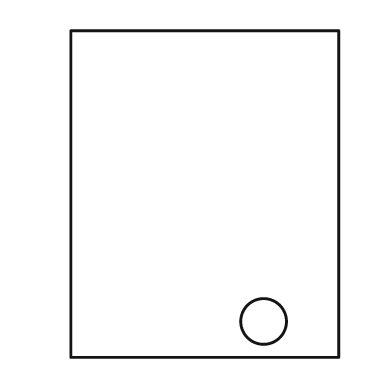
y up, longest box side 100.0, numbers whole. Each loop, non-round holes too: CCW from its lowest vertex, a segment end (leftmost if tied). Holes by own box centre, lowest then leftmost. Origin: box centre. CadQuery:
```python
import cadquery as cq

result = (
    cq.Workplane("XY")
    .moveTo(-41.0, -50.0)
    .lineTo(41.0, -50.0)
    .lineTo(41.0, 50.0)
    .lineTo(-41.0, 50.0)
    .close()
    .moveTo(18.0, -39.0)
    .circle(7.0)
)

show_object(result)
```